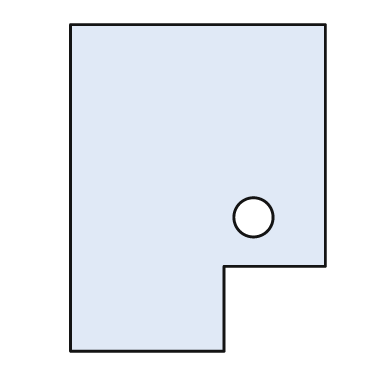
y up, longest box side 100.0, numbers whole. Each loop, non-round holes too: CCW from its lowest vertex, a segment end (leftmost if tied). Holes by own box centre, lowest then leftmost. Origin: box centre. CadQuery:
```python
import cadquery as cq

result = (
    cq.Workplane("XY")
    .moveTo(-39.0, -50.0)
    .lineTo(8.0, -50.0)
    .lineTo(8.0, -24.0)
    .lineTo(39.0, -24.0)
    .lineTo(39.0, 50.0)
    .lineTo(-39.0, 50.0)
    .close()
    .moveTo(17.0, -9.0)
    .circle(6.0)
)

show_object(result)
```